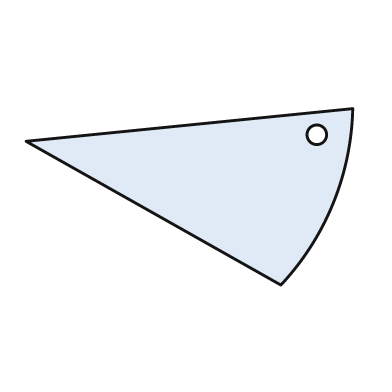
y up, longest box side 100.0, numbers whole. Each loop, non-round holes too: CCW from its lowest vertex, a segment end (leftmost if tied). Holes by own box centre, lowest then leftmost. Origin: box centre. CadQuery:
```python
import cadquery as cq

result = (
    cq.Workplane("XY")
    .moveTo(28.0, -27.0)
    .threePointArc((44.0, -2.0), (50.0, 27.0))
    .lineTo(-50.0, 17.0)
    .close()
    .moveTo(39.0, 19.0)
    .circle(3.0)
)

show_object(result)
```